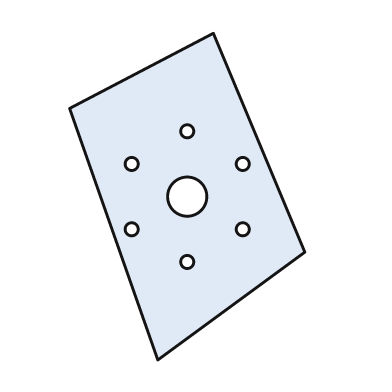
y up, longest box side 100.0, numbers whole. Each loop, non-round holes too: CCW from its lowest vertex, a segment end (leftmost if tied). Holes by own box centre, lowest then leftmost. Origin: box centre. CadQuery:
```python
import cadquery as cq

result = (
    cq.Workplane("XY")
    .moveTo(-9.0, -50.0)
    .lineTo(36.0, -17.0)
    .lineTo(8.0, 50.0)
    .lineTo(-36.0, 27.0)
    .close()
    .moveTo(0.0, -20.0)
    .circle(2.0)
    .moveTo(-17.0, -10.0)
    .circle(2.0)
    .moveTo(17.0, -10.0)
    .circle(2.0)
    .moveTo(0.0, 0.0)
    .circle(6.0)
    .moveTo(-17.0, 10.0)
    .circle(2.0)
    .moveTo(17.0, 10.0)
    .circle(2.0)
    .moveTo(0.0, 20.0)
    .circle(2.0)
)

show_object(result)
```